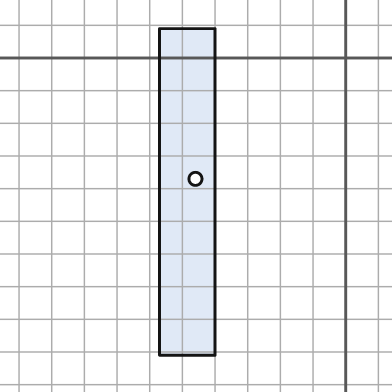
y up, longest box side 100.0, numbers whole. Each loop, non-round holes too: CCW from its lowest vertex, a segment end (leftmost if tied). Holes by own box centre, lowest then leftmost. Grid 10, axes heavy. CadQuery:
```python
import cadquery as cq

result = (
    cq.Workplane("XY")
    .moveTo(-57.0, -91.0)
    .lineTo(-40.0, -91.0)
    .lineTo(-40.0, 9.0)
    .lineTo(-57.0, 9.0)
    .close()
    .moveTo(-46.0, -37.0)
    .circle(2.0)
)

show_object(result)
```